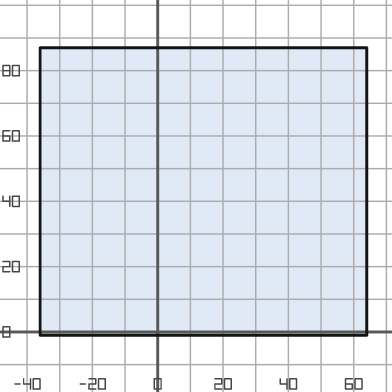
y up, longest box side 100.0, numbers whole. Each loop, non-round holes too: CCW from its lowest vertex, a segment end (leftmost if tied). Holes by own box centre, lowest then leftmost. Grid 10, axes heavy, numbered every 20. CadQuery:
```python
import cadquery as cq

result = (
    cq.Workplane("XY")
    .moveTo(-36.0, -1.0)
    .lineTo(64.0, -1.0)
    .lineTo(64.0, 87.0)
    .lineTo(-36.0, 87.0)
    .close()
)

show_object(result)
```